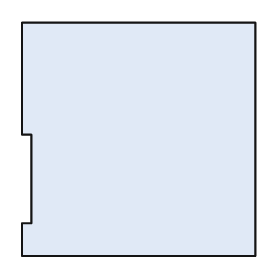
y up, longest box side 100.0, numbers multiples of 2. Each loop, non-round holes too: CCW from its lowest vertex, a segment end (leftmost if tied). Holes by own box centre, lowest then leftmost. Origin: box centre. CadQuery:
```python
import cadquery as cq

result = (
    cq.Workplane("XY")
    .moveTo(-50.0, -50.0)
    .lineTo(50.0, -50.0)
    .lineTo(50.0, 50.0)
    .lineTo(-50.0, 50.0)
    .lineTo(-50.0, 2.0)
    .lineTo(-46.0, 2.0)
    .lineTo(-46.0, -36.0)
    .lineTo(-50.0, -36.0)
    .close()
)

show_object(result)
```